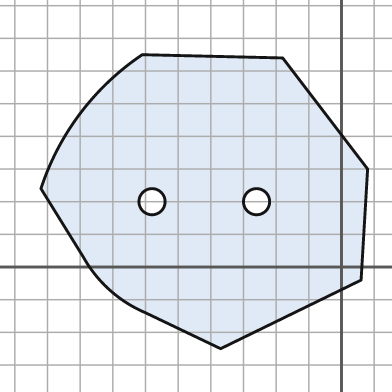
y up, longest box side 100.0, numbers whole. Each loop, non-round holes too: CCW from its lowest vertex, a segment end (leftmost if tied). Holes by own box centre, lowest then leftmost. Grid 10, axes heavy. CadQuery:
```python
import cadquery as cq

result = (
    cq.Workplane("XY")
    .moveTo(-37.0, -25.0)
    .lineTo(6.0, -4.0)
    .lineTo(8.0, 30.0)
    .lineTo(-18.0, 64.0)
    .lineTo(-61.0, 65.0)
    .threePointArc((-80.0, 47.0), (-92.0, 24.0))
    .lineTo(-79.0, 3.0)
    .threePointArc((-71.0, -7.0), (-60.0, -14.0))
    .close()
    .moveTo(-58.0, 20.0)
    .circle(4.0)
    .moveTo(-26.0, 20.0)
    .circle(4.0)
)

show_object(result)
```